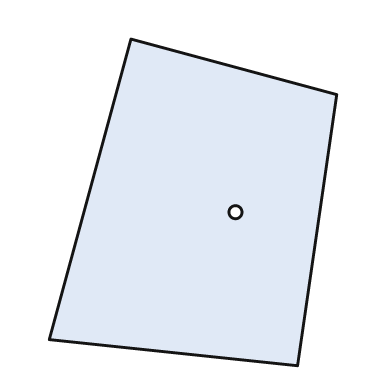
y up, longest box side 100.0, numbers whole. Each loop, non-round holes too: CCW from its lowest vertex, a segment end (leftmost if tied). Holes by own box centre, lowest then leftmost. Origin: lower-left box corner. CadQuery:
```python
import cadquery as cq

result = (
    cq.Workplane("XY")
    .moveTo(76.0, 0.0)
    .lineTo(88.0, 83.0)
    .lineTo(25.0, 100.0)
    .lineTo(0.0, 8.0)
    .close()
    .moveTo(57.0, 47.0)
    .circle(2.0)
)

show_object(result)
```